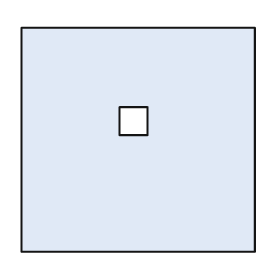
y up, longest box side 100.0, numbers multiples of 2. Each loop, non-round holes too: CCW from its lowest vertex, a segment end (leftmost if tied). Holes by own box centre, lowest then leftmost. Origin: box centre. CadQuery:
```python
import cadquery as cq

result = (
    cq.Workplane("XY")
    .moveTo(-50.0, -48.0)
    .lineTo(50.0, -48.0)
    .lineTo(50.0, 48.0)
    .lineTo(-50.0, 48.0)
    .close()
    .moveTo(-8.0, 2.0)
    .lineTo(4.0, 2.0)
    .lineTo(4.0, 14.0)
    .lineTo(-8.0, 14.0)
    .close()
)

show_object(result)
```